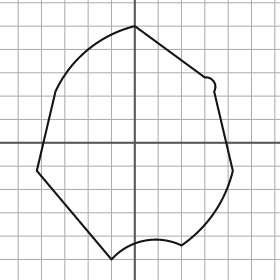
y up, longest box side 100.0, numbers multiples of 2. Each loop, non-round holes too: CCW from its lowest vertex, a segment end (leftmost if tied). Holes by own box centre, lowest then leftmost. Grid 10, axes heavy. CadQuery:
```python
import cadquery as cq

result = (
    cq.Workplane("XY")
    .moveTo(-10.0, -50.0)
    .threePointArc((4.0, -42.0), (20.0, -44.0))
    .threePointArc((34.0, -30.0), (42.0, -12.0))
    .lineTo(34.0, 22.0)
    .threePointArc((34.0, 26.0), (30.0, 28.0))
    .lineTo(0.0, 50.0)
    .threePointArc((-20.0, 40.0), (-34.0, 22.0))
    .lineTo(-42.0, -12.0)
    .close()
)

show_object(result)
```